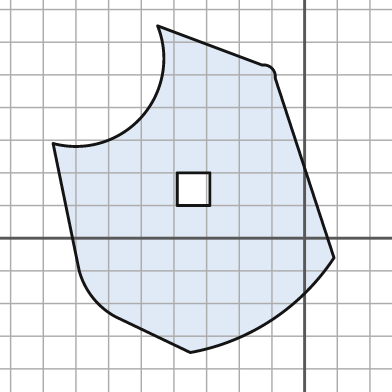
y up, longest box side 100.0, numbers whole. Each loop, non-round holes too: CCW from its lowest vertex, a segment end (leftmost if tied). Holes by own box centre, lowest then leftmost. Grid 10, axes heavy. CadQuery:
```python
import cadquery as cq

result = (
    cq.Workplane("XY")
    .moveTo(-35.0, -35.0)
    .threePointArc((-10.0, -25.0), (9.0, -6.0))
    .lineTo(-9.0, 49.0)
    .threePointArc((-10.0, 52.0), (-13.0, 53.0))
    .lineTo(-45.0, 65.0)
    .threePointArc((-50.0, 37.0), (-77.0, 29.0))
    .lineTo(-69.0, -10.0)
    .threePointArc((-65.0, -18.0), (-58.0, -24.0))
    .close()
    .moveTo(-39.0, 10.0)
    .lineTo(-29.0, 10.0)
    .lineTo(-29.0, 20.0)
    .lineTo(-39.0, 20.0)
    .close()
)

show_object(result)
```